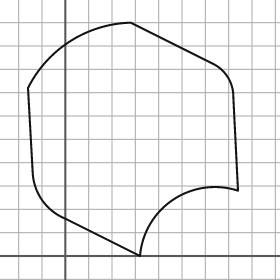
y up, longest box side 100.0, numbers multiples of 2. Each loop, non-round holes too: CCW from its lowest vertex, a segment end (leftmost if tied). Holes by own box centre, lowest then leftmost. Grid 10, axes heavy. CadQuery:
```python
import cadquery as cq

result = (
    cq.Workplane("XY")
    .moveTo(32.0, 0.0)
    .threePointArc((46.0, 24.0), (74.0, 28.0))
    .lineTo(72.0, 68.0)
    .threePointArc((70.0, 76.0), (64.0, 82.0))
    .lineTo(28.0, 100.0)
    .threePointArc((2.0, 92.0), (-16.0, 72.0))
    .lineTo(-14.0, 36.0)
    .threePointArc((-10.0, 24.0), (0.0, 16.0))
    .close()
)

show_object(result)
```